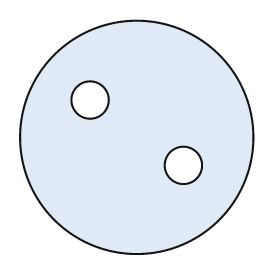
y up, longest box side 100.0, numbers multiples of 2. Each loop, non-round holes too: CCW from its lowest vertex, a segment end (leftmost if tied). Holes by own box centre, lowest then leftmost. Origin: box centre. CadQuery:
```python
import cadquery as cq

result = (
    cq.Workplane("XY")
    .moveTo(0.0, 0.0)
    .circle(50.0)
    .moveTo(20.0, -12.0)
    .circle(8.0)
    .moveTo(-20.0, 16.0)
    .circle(8.0)
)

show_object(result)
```